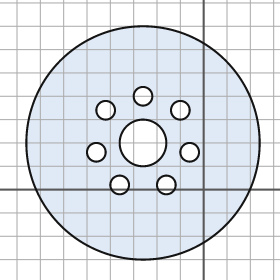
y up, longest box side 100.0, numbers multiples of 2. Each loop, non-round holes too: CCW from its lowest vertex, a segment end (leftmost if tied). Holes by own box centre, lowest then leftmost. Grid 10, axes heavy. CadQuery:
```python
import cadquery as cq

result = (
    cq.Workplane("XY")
    .moveTo(-26.0, 20.0)
    .circle(50.0)
    .moveTo(-36.0, 2.0)
    .circle(4.0)
    .moveTo(-16.0, 2.0)
    .circle(4.0)
    .moveTo(-46.0, 16.0)
    .circle(4.0)
    .moveTo(-6.0, 16.0)
    .circle(4.0)
    .moveTo(-26.0, 20.0)
    .circle(10.0)
    .moveTo(-42.0, 34.0)
    .circle(4.0)
    .moveTo(-10.0, 34.0)
    .circle(4.0)
    .moveTo(-26.0, 40.0)
    .circle(4.0)
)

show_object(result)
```